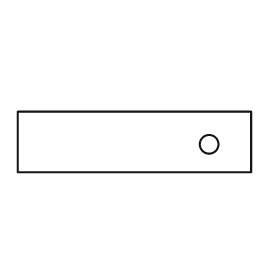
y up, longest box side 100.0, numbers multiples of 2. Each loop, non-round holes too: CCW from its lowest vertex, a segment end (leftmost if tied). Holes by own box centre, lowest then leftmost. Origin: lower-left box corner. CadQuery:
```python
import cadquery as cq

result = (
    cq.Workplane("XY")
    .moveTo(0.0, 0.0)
    .lineTo(100.0, 0.0)
    .lineTo(100.0, 26.0)
    .lineTo(0.0, 26.0)
    .close()
    .moveTo(82.0, 12.0)
    .circle(4.0)
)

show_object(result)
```